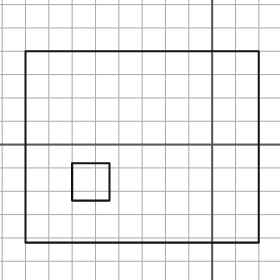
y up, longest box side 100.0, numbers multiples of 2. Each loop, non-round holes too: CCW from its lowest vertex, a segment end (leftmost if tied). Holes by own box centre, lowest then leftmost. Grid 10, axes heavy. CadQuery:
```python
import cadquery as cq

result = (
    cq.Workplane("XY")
    .moveTo(-80.0, -42.0)
    .lineTo(20.0, -42.0)
    .lineTo(20.0, 40.0)
    .lineTo(-80.0, 40.0)
    .close()
    .moveTo(-60.0, -24.0)
    .lineTo(-44.0, -24.0)
    .lineTo(-44.0, -8.0)
    .lineTo(-60.0, -8.0)
    .close()
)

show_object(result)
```